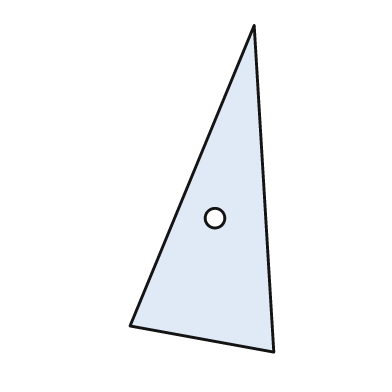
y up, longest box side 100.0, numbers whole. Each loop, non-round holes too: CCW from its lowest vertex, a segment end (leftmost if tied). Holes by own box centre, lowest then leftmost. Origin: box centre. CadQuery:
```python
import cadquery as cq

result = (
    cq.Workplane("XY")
    .moveTo(22.0, -50.0)
    .lineTo(16.0, 50.0)
    .lineTo(-22.0, -42.0)
    .close()
    .moveTo(4.0, -9.0)
    .circle(3.0)
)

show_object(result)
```